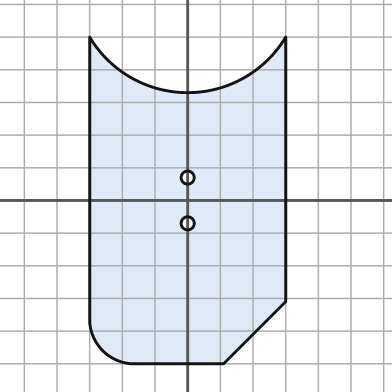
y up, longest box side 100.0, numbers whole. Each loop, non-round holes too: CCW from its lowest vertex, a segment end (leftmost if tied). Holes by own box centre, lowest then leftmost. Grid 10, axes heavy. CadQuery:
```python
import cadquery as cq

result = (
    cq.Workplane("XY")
    .moveTo(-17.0, -50.0)
    .lineTo(11.0, -50.0)
    .lineTo(30.0, -31.0)
    .lineTo(30.0, 50.0)
    .threePointArc((0.0, 33.0), (-30.0, 50.0))
    .lineTo(-30.0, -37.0)
    .threePointArc((-26.0, -46.0), (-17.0, -50.0))
    .close()
    .moveTo(0.0, -7.0)
    .circle(2.0)
    .moveTo(0.0, 7.0)
    .circle(2.0)
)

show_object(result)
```